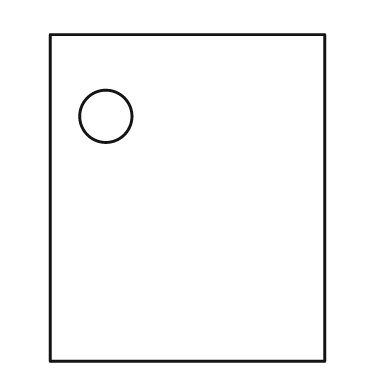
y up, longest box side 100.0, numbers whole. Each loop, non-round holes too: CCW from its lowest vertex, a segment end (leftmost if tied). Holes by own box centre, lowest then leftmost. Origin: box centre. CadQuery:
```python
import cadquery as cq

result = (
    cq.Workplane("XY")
    .moveTo(-42.0, -50.0)
    .lineTo(42.0, -50.0)
    .lineTo(42.0, 50.0)
    .lineTo(-42.0, 50.0)
    .close()
    .moveTo(-25.0, 25.0)
    .circle(8.0)
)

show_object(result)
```